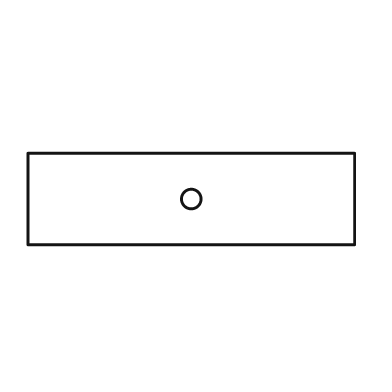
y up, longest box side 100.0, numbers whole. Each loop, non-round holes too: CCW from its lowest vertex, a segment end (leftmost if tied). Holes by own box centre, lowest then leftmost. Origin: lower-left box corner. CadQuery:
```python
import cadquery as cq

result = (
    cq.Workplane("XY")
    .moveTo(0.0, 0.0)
    .lineTo(100.0, 0.0)
    .lineTo(100.0, 28.0)
    .lineTo(0.0, 28.0)
    .close()
    .moveTo(50.0, 14.0)
    .circle(3.0)
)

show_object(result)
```